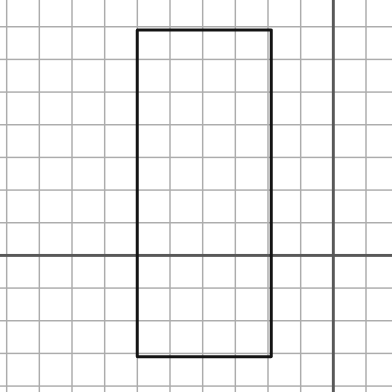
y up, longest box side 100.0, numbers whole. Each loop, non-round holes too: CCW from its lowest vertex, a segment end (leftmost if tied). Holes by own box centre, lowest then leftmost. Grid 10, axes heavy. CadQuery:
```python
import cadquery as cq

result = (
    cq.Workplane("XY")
    .moveTo(-60.0, -31.0)
    .lineTo(-19.0, -31.0)
    .lineTo(-19.0, 69.0)
    .lineTo(-60.0, 69.0)
    .close()
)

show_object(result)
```